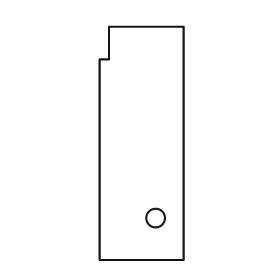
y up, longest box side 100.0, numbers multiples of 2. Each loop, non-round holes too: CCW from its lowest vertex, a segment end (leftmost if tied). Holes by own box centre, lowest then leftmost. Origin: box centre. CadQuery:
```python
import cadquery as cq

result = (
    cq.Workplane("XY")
    .moveTo(-18.0, -50.0)
    .lineTo(18.0, -50.0)
    .lineTo(18.0, 50.0)
    .lineTo(-14.0, 50.0)
    .lineTo(-14.0, 36.0)
    .lineTo(-18.0, 36.0)
    .close()
    .moveTo(6.0, -32.0)
    .circle(4.0)
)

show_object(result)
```